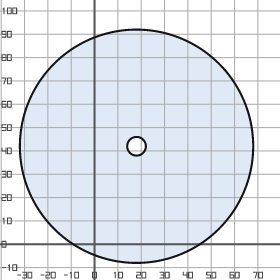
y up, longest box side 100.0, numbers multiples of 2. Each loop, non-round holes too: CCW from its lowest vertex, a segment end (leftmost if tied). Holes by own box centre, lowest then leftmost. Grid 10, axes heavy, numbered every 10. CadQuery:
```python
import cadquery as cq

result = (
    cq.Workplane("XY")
    .moveTo(18.0, 42.0)
    .circle(50.0)
    .moveTo(18.0, 42.0)
    .circle(4.0)
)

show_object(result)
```